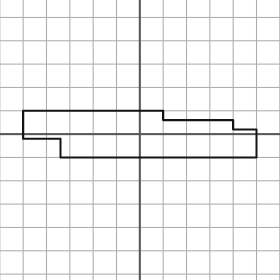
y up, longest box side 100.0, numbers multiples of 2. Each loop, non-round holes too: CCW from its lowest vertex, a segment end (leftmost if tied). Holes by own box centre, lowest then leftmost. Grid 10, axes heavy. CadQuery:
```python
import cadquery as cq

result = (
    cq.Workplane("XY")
    .moveTo(-34.0, -10.0)
    .lineTo(50.0, -10.0)
    .lineTo(50.0, 2.0)
    .lineTo(40.0, 2.0)
    .lineTo(40.0, 6.0)
    .lineTo(10.0, 6.0)
    .lineTo(10.0, 10.0)
    .lineTo(-50.0, 10.0)
    .lineTo(-50.0, -2.0)
    .lineTo(-34.0, -2.0)
    .close()
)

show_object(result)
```